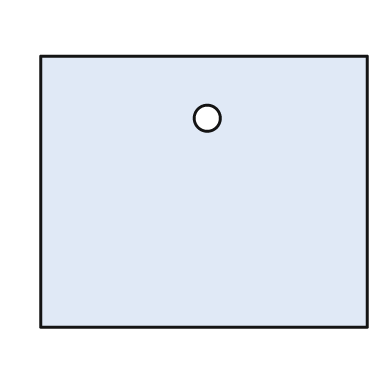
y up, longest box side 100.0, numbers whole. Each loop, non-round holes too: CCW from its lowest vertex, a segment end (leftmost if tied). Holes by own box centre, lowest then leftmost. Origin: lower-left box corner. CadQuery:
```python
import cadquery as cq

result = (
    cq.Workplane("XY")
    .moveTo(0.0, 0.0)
    .lineTo(100.0, 0.0)
    .lineTo(100.0, 83.0)
    .lineTo(0.0, 83.0)
    .close()
    .moveTo(51.0, 64.0)
    .circle(4.0)
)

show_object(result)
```